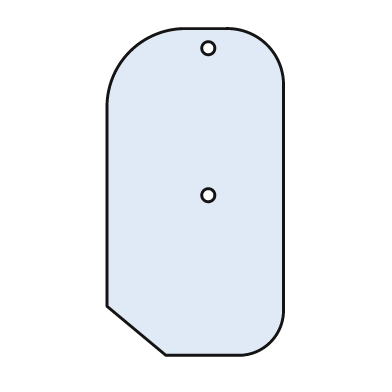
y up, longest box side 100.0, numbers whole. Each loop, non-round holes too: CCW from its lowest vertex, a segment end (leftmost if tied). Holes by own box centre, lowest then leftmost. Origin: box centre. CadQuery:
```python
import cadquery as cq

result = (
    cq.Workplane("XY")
    .moveTo(-9.0, -50.0)
    .lineTo(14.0, -50.0)
    .threePointArc((23.0, -46.0), (27.0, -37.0))
    .lineTo(27.0, 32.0)
    .threePointArc((22.0, 45.0), (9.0, 50.0))
    .lineTo(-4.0, 50.0)
    .threePointArc((-20.0, 43.0), (-27.0, 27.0))
    .lineTo(-27.0, -35.0)
    .close()
    .moveTo(4.0, -1.0)
    .circle(2.0)
    .moveTo(4.0, 44.0)
    .circle(2.0)
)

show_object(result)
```